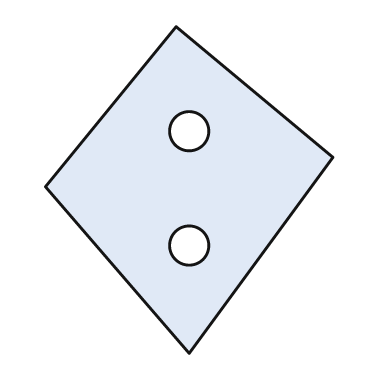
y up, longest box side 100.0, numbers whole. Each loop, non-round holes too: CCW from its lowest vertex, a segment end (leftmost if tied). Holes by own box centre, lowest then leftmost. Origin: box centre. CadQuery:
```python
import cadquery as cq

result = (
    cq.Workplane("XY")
    .moveTo(0.0, -50.0)
    .lineTo(44.0, 10.0)
    .lineTo(-4.0, 50.0)
    .lineTo(-44.0, 1.0)
    .close()
    .moveTo(0.0, -17.0)
    .circle(6.0)
    .moveTo(0.0, 18.0)
    .circle(6.0)
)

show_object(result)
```